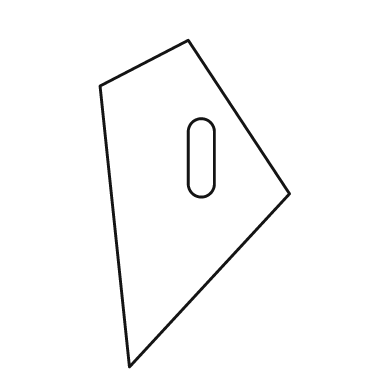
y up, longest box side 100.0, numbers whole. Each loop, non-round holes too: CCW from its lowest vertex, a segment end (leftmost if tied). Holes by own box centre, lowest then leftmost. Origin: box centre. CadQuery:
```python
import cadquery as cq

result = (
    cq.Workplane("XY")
    .moveTo(-20.0, -50.0)
    .lineTo(29.0, 3.0)
    .lineTo(-2.0, 50.0)
    .lineTo(-29.0, 36.0)
    .close()
    .moveTo(-2.0, 6.0)
    .threePointArc((2.0, 2.0), (6.0, 6.0))
    .lineTo(6.0, 22.0)
    .threePointArc((2.0, 26.0), (-2.0, 22.0))
    .close()
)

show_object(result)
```